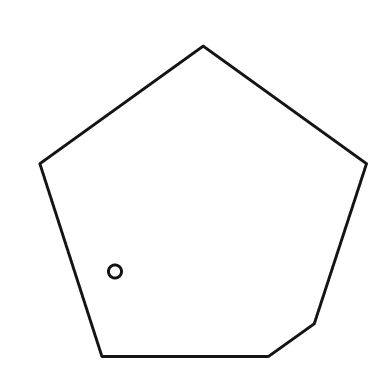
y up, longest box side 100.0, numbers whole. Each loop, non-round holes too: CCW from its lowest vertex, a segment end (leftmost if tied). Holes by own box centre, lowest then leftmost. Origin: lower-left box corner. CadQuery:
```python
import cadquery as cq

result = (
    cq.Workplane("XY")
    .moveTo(19.0, 0.0)
    .lineTo(70.0, 0.0)
    .lineTo(84.0, 10.0)
    .lineTo(100.0, 59.0)
    .lineTo(50.0, 95.0)
    .lineTo(0.0, 59.0)
    .close()
    .moveTo(23.0, 26.0)
    .circle(2.0)
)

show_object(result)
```